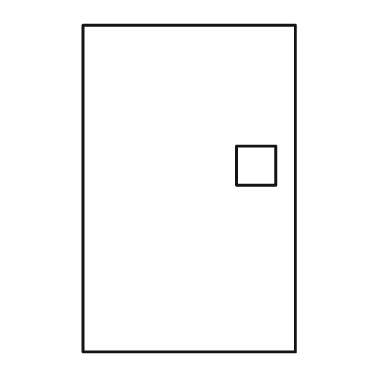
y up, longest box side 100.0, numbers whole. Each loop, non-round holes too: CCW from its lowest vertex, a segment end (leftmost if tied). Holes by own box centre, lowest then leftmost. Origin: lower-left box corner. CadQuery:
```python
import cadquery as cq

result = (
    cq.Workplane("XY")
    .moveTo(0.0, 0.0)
    .lineTo(65.0, 0.0)
    .lineTo(65.0, 100.0)
    .lineTo(0.0, 100.0)
    .close()
    .moveTo(47.0, 51.0)
    .lineTo(59.0, 51.0)
    .lineTo(59.0, 63.0)
    .lineTo(47.0, 63.0)
    .close()
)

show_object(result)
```